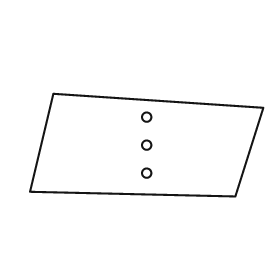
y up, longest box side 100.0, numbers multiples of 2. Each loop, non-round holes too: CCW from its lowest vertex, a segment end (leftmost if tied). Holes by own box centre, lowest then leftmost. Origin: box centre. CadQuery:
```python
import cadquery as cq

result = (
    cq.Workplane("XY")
    .moveTo(38.0, -22.0)
    .lineTo(50.0, 16.0)
    .lineTo(-40.0, 22.0)
    .lineTo(-50.0, -20.0)
    .close()
    .moveTo(0.0, -12.0)
    .circle(2.0)
    .moveTo(0.0, 0.0)
    .circle(2.0)
    .moveTo(0.0, 12.0)
    .circle(2.0)
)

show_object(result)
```